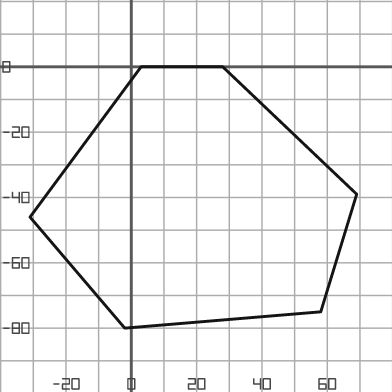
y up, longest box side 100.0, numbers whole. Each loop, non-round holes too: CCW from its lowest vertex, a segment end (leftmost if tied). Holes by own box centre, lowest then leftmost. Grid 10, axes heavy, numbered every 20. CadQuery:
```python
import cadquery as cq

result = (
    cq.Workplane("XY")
    .moveTo(-2.0, -80.0)
    .lineTo(58.0, -75.0)
    .lineTo(69.0, -39.0)
    .lineTo(28.0, 0.0)
    .lineTo(3.0, 0.0)
    .lineTo(-31.0, -46.0)
    .close()
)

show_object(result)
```